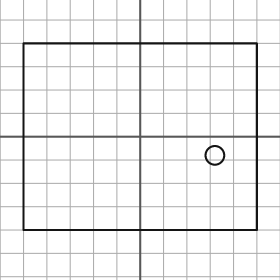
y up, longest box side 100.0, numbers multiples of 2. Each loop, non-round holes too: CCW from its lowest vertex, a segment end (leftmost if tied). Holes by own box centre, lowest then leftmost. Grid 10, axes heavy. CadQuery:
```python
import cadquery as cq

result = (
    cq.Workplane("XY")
    .moveTo(-50.0, -40.0)
    .lineTo(50.0, -40.0)
    .lineTo(50.0, 40.0)
    .lineTo(-50.0, 40.0)
    .close()
    .moveTo(32.0, -8.0)
    .circle(4.0)
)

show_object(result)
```